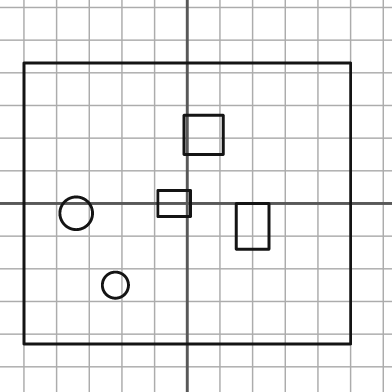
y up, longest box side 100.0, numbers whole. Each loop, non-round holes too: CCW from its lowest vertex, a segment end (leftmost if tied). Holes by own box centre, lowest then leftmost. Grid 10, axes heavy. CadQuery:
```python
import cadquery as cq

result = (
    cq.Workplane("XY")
    .moveTo(-50.0, -43.0)
    .lineTo(50.0, -43.0)
    .lineTo(50.0, 43.0)
    .lineTo(-50.0, 43.0)
    .close()
    .moveTo(-22.0, -25.0)
    .circle(4.0)
    .moveTo(15.0, -14.0)
    .lineTo(25.0, -14.0)
    .lineTo(25.0, 0.0)
    .lineTo(15.0, 0.0)
    .close()
    .moveTo(-34.0, -3.0)
    .circle(5.0)
    .moveTo(-9.0, -4.0)
    .lineTo(1.0, -4.0)
    .lineTo(1.0, 4.0)
    .lineTo(-9.0, 4.0)
    .close()
    .moveTo(-1.0, 15.0)
    .lineTo(11.0, 15.0)
    .lineTo(11.0, 27.0)
    .lineTo(-1.0, 27.0)
    .close()
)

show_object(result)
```